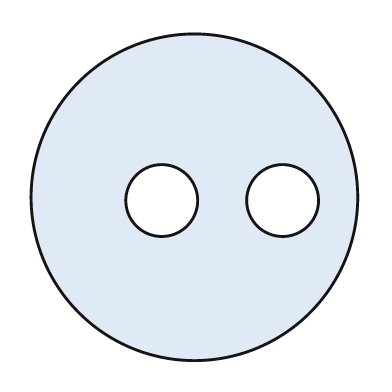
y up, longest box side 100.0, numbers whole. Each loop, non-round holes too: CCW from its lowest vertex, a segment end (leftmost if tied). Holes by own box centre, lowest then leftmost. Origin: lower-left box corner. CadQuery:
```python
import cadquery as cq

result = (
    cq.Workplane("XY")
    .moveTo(50.0, 50.0)
    .circle(50.0)
    .moveTo(40.0, 49.0)
    .circle(11.0)
    .moveTo(77.0, 49.0)
    .circle(11.0)
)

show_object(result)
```